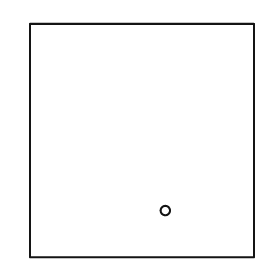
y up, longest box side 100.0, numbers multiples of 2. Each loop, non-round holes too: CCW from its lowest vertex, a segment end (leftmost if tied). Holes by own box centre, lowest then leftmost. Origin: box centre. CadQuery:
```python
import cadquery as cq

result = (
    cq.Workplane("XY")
    .moveTo(-48.0, -50.0)
    .lineTo(48.0, -50.0)
    .lineTo(48.0, 50.0)
    .lineTo(-48.0, 50.0)
    .close()
    .moveTo(10.0, -30.0)
    .circle(2.0)
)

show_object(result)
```